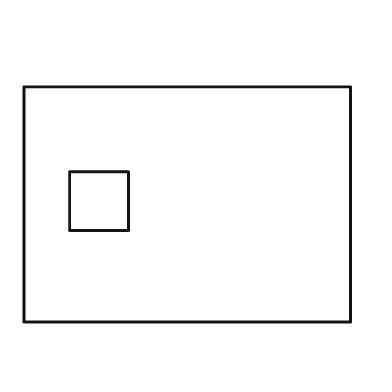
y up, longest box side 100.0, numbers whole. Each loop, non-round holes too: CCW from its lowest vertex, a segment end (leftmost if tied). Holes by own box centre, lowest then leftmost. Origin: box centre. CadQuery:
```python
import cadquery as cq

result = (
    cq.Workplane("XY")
    .moveTo(-50.0, -36.0)
    .lineTo(50.0, -36.0)
    .lineTo(50.0, 36.0)
    .lineTo(-50.0, 36.0)
    .close()
    .moveTo(-36.0, -8.0)
    .lineTo(-18.0, -8.0)
    .lineTo(-18.0, 10.0)
    .lineTo(-36.0, 10.0)
    .close()
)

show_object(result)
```